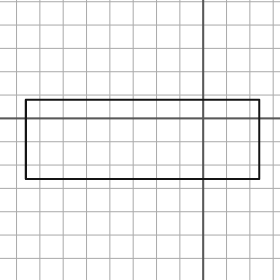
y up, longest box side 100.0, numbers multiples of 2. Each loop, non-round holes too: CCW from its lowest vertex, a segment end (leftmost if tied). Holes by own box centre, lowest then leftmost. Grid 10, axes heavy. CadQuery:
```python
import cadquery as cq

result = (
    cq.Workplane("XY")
    .moveTo(-76.0, -26.0)
    .lineTo(24.0, -26.0)
    .lineTo(24.0, 8.0)
    .lineTo(-76.0, 8.0)
    .close()
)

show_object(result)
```